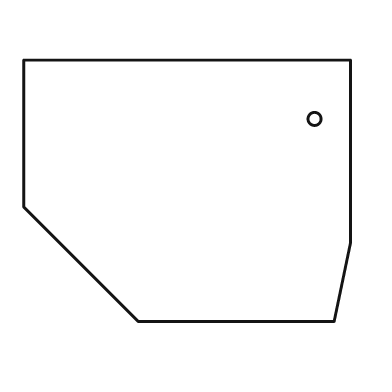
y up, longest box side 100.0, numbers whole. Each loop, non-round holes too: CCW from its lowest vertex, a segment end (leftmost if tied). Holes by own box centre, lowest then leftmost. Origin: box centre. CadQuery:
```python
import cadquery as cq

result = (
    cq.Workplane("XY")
    .moveTo(-15.0, -40.0)
    .lineTo(45.0, -40.0)
    .lineTo(50.0, -16.0)
    .lineTo(50.0, 40.0)
    .lineTo(-50.0, 40.0)
    .lineTo(-50.0, -5.0)
    .close()
    .moveTo(39.0, 22.0)
    .circle(2.0)
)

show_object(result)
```